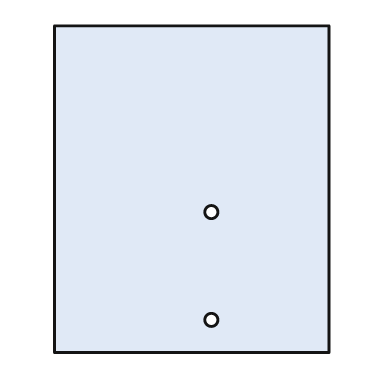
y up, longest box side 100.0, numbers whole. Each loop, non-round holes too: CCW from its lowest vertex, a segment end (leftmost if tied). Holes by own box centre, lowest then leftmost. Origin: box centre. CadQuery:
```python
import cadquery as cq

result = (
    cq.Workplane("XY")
    .moveTo(-42.0, -50.0)
    .lineTo(42.0, -50.0)
    .lineTo(42.0, 50.0)
    .lineTo(-42.0, 50.0)
    .close()
    .moveTo(6.0, -40.0)
    .circle(2.0)
    .moveTo(6.0, -7.0)
    .circle(2.0)
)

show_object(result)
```